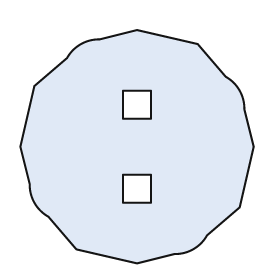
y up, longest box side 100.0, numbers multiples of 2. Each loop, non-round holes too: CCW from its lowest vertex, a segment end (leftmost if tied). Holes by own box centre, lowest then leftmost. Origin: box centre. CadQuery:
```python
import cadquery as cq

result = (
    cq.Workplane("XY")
    .moveTo(0.0, -50.0)
    .lineTo(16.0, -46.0)
    .threePointArc((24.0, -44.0), (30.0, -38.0))
    .lineTo(44.0, -26.0)
    .lineTo(50.0, 0.0)
    .lineTo(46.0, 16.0)
    .threePointArc((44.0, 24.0), (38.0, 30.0))
    .lineTo(26.0, 44.0)
    .lineTo(0.0, 50.0)
    .lineTo(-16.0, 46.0)
    .threePointArc((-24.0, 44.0), (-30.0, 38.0))
    .lineTo(-44.0, 26.0)
    .lineTo(-50.0, 0.0)
    .lineTo(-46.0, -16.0)
    .threePointArc((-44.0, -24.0), (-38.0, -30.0))
    .lineTo(-26.0, -44.0)
    .close()
    .moveTo(-6.0, -24.0)
    .lineTo(6.0, -24.0)
    .lineTo(6.0, -12.0)
    .lineTo(-6.0, -12.0)
    .close()
    .moveTo(-6.0, 12.0)
    .lineTo(6.0, 12.0)
    .lineTo(6.0, 24.0)
    .lineTo(-6.0, 24.0)
    .close()
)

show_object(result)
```